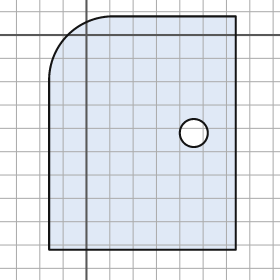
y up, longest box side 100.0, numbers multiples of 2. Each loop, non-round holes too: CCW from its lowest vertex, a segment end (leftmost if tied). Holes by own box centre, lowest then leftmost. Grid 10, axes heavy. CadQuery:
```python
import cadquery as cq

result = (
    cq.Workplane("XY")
    .moveTo(-16.0, -92.0)
    .lineTo(64.0, -92.0)
    .lineTo(64.0, 8.0)
    .lineTo(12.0, 8.0)
    .threePointArc((-8.0, 0.0), (-16.0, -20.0))
    .close()
    .moveTo(46.0, -42.0)
    .circle(6.0)
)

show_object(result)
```